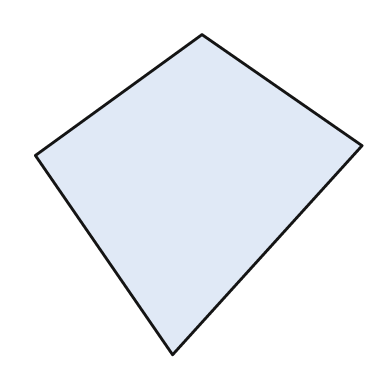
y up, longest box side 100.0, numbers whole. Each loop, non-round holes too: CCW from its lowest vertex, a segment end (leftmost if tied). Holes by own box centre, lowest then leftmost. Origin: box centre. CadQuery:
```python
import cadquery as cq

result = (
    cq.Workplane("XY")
    .moveTo(-8.0, -49.0)
    .lineTo(50.0, 15.0)
    .lineTo(1.0, 49.0)
    .lineTo(-50.0, 12.0)
    .close()
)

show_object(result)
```